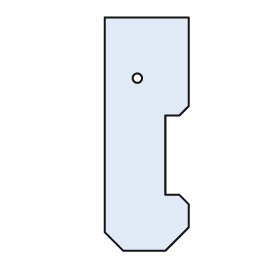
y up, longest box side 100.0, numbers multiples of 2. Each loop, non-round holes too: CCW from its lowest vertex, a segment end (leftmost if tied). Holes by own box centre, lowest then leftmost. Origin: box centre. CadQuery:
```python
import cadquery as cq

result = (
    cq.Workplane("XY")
    .moveTo(-10.0, -50.0)
    .lineTo(8.0, -50.0)
    .lineTo(18.0, -40.0)
    .lineTo(18.0, -30.0)
    .lineTo(14.0, -26.0)
    .lineTo(8.0, -26.0)
    .lineTo(8.0, 8.0)
    .lineTo(14.0, 8.0)
    .lineTo(18.0, 12.0)
    .lineTo(18.0, 50.0)
    .lineTo(-18.0, 50.0)
    .lineTo(-18.0, -42.0)
    .close()
    .moveTo(-4.0, 24.0)
    .circle(2.0)
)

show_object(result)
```